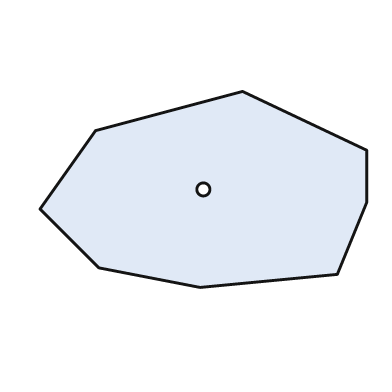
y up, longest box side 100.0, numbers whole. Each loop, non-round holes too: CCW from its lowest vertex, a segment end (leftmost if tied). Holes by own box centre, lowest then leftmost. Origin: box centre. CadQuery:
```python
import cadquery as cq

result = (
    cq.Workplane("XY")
    .moveTo(-1.0, -30.0)
    .lineTo(41.0, -26.0)
    .lineTo(50.0, -4.0)
    .lineTo(50.0, 12.0)
    .lineTo(12.0, 30.0)
    .lineTo(-33.0, 18.0)
    .lineTo(-50.0, -6.0)
    .lineTo(-32.0, -24.0)
    .close()
    .moveTo(0.0, 0.0)
    .circle(2.0)
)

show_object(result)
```